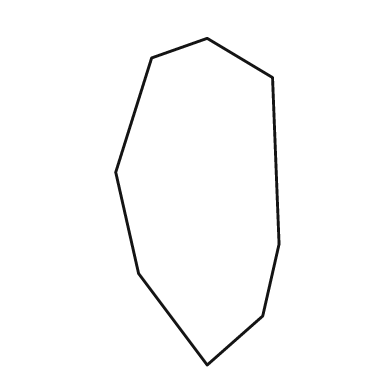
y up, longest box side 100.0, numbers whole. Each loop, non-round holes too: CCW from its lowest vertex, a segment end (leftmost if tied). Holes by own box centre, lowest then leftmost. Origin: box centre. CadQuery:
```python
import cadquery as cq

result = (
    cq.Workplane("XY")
    .moveTo(3.0, -50.0)
    .lineTo(20.0, -35.0)
    .lineTo(25.0, -13.0)
    .lineTo(23.0, 38.0)
    .lineTo(3.0, 50.0)
    .lineTo(-14.0, 44.0)
    .lineTo(-25.0, 9.0)
    .lineTo(-18.0, -22.0)
    .close()
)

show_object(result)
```